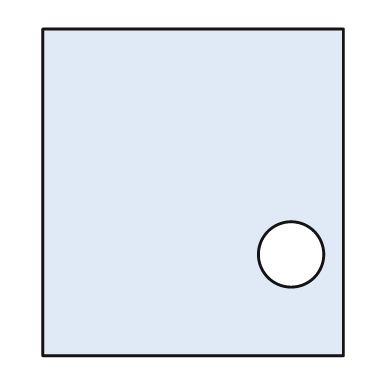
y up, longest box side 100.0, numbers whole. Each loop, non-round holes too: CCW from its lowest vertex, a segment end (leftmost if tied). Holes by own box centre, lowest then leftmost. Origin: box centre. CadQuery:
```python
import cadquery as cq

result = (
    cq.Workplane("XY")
    .moveTo(-46.0, -50.0)
    .lineTo(46.0, -50.0)
    .lineTo(46.0, 50.0)
    .lineTo(-46.0, 50.0)
    .close()
    .moveTo(30.0, -19.0)
    .circle(10.0)
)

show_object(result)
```